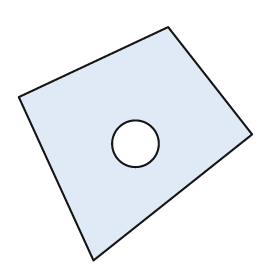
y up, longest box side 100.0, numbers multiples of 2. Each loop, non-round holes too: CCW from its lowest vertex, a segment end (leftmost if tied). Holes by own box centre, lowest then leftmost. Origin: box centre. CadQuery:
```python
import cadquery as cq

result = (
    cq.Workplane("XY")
    .moveTo(-18.0, -50.0)
    .lineTo(50.0, 4.0)
    .lineTo(14.0, 50.0)
    .lineTo(-50.0, 20.0)
    .close()
    .moveTo(0.0, 0.0)
    .circle(10.0)
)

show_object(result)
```